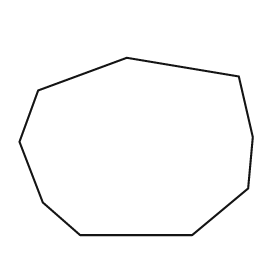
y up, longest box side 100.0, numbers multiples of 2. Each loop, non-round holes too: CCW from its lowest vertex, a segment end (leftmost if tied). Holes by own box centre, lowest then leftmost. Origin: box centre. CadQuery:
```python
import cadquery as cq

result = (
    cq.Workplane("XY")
    .moveTo(-24.0, -38.0)
    .lineTo(24.0, -38.0)
    .lineTo(48.0, -18.0)
    .lineTo(50.0, 4.0)
    .lineTo(44.0, 30.0)
    .lineTo(-4.0, 38.0)
    .lineTo(-42.0, 24.0)
    .lineTo(-50.0, 2.0)
    .lineTo(-40.0, -24.0)
    .close()
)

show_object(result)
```